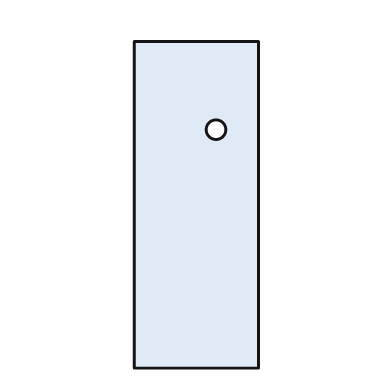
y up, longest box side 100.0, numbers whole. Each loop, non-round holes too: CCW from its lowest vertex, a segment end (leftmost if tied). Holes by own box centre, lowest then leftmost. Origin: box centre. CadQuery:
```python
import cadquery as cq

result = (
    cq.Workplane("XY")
    .moveTo(-19.0, -50.0)
    .lineTo(19.0, -50.0)
    .lineTo(19.0, 50.0)
    .lineTo(-19.0, 50.0)
    .close()
    .moveTo(6.0, 23.0)
    .circle(3.0)
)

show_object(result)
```